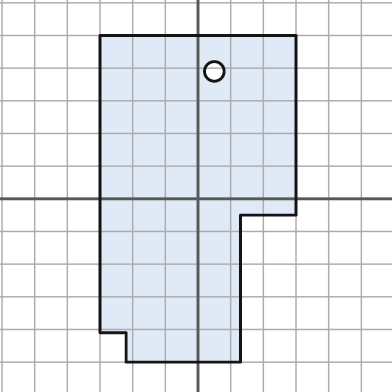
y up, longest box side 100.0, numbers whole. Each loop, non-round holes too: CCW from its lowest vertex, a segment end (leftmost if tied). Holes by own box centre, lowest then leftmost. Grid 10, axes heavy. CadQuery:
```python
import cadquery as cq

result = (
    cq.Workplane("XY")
    .moveTo(-22.0, -50.0)
    .lineTo(13.0, -50.0)
    .lineTo(13.0, -5.0)
    .lineTo(30.0, -5.0)
    .lineTo(30.0, 50.0)
    .lineTo(-30.0, 50.0)
    .lineTo(-30.0, -41.0)
    .lineTo(-22.0, -41.0)
    .close()
    .moveTo(5.0, 39.0)
    .circle(3.0)
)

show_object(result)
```